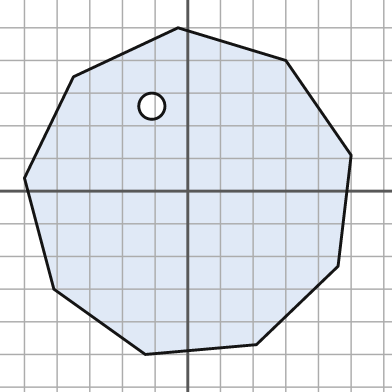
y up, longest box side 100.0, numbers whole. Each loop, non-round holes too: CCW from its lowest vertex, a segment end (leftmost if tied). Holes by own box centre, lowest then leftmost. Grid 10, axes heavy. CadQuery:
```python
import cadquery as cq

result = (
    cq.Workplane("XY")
    .moveTo(-13.0, -50.0)
    .lineTo(21.0, -47.0)
    .lineTo(46.0, -23.0)
    .lineTo(50.0, 11.0)
    .lineTo(30.0, 40.0)
    .lineTo(-3.0, 50.0)
    .lineTo(-35.0, 35.0)
    .lineTo(-50.0, 4.0)
    .lineTo(-41.0, -30.0)
    .close()
    .moveTo(-11.0, 26.0)
    .circle(4.0)
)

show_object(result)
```